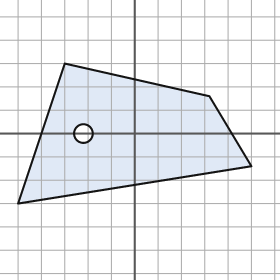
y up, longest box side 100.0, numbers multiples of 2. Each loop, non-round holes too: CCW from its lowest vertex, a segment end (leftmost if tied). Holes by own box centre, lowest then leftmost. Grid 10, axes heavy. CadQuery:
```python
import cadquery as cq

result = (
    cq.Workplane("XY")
    .moveTo(-50.0, -30.0)
    .lineTo(50.0, -14.0)
    .lineTo(32.0, 16.0)
    .lineTo(-30.0, 30.0)
    .close()
    .moveTo(-22.0, 0.0)
    .circle(4.0)
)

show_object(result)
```